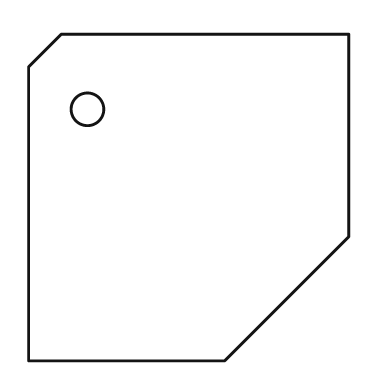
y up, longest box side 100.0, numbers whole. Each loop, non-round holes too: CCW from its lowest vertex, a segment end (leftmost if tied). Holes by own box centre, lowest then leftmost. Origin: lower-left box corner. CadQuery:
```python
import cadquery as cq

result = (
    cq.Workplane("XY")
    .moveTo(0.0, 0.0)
    .lineTo(60.0, 0.0)
    .lineTo(98.0, 38.0)
    .lineTo(98.0, 100.0)
    .lineTo(10.0, 100.0)
    .lineTo(0.0, 90.0)
    .close()
    .moveTo(18.0, 77.0)
    .circle(5.0)
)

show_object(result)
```